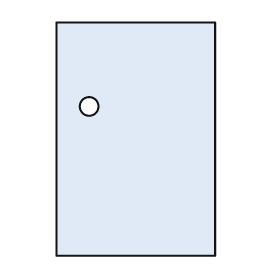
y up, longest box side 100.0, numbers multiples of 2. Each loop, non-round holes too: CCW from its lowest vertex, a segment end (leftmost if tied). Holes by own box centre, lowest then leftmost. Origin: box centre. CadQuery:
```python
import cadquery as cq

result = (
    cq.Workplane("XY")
    .moveTo(-34.0, -50.0)
    .lineTo(34.0, -50.0)
    .lineTo(34.0, 50.0)
    .lineTo(-34.0, 50.0)
    .close()
    .moveTo(-20.0, 14.0)
    .circle(4.0)
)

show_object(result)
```